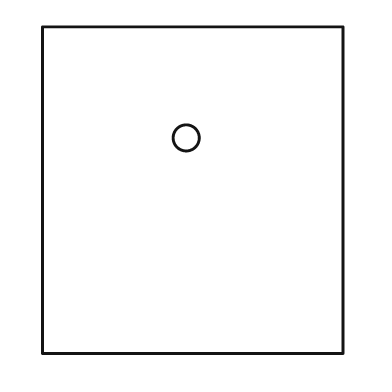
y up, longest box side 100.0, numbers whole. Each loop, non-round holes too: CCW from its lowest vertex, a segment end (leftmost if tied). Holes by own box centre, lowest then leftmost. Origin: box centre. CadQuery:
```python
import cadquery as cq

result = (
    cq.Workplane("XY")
    .moveTo(-46.0, -50.0)
    .lineTo(46.0, -50.0)
    .lineTo(46.0, 50.0)
    .lineTo(-46.0, 50.0)
    .close()
    .moveTo(-2.0, 16.0)
    .circle(4.0)
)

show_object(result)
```